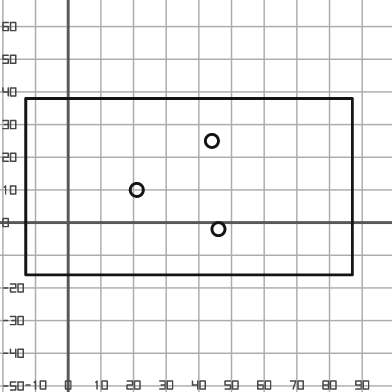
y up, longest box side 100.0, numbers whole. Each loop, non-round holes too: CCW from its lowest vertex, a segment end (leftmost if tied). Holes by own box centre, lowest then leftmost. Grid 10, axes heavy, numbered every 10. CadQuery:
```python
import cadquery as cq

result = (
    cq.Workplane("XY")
    .moveTo(-13.0, -16.0)
    .lineTo(87.0, -16.0)
    .lineTo(87.0, 38.0)
    .lineTo(-13.0, 38.0)
    .close()
    .moveTo(46.0, -2.0)
    .circle(2.0)
    .moveTo(21.0, 10.0)
    .circle(2.0)
    .moveTo(44.0, 25.0)
    .circle(2.0)
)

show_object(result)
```